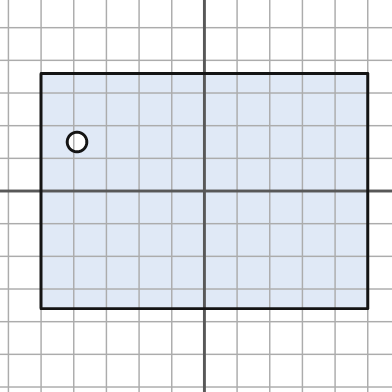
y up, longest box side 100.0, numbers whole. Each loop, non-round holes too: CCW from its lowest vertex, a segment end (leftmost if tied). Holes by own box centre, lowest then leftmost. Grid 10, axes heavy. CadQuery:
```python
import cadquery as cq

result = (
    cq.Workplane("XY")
    .moveTo(-50.0, -36.0)
    .lineTo(50.0, -36.0)
    .lineTo(50.0, 36.0)
    .lineTo(-50.0, 36.0)
    .close()
    .moveTo(-39.0, 15.0)
    .circle(3.0)
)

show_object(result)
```